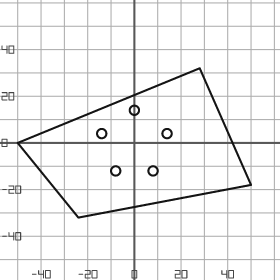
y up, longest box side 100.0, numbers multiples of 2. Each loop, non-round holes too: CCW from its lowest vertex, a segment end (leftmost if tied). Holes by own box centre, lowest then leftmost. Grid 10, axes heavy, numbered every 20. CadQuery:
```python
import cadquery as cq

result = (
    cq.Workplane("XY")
    .moveTo(-24.0, -32.0)
    .lineTo(50.0, -18.0)
    .lineTo(28.0, 32.0)
    .lineTo(-50.0, 0.0)
    .close()
    .moveTo(-8.0, -12.0)
    .circle(2.0)
    .moveTo(8.0, -12.0)
    .circle(2.0)
    .moveTo(-14.0, 4.0)
    .circle(2.0)
    .moveTo(14.0, 4.0)
    .circle(2.0)
    .moveTo(0.0, 14.0)
    .circle(2.0)
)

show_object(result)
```